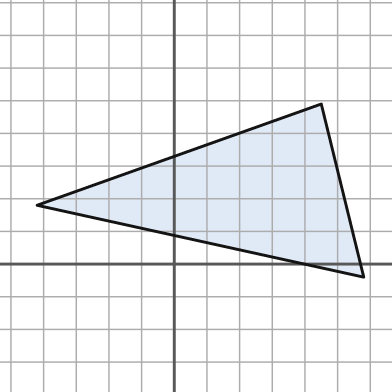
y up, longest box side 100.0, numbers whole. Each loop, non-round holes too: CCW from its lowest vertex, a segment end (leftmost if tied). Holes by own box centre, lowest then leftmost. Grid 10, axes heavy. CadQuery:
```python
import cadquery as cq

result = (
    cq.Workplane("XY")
    .moveTo(58.0, -4.0)
    .lineTo(45.0, 49.0)
    .lineTo(-42.0, 18.0)
    .close()
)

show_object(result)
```